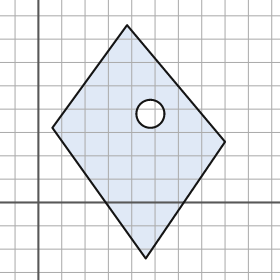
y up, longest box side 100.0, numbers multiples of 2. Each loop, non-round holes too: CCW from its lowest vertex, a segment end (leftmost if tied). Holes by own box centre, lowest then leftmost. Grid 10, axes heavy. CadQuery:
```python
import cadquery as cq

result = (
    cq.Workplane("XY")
    .moveTo(46.0, -24.0)
    .lineTo(80.0, 26.0)
    .lineTo(38.0, 76.0)
    .lineTo(6.0, 32.0)
    .close()
    .moveTo(48.0, 38.0)
    .circle(6.0)
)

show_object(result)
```